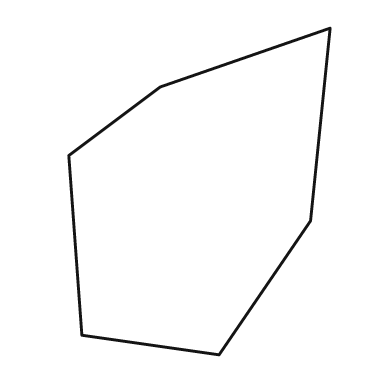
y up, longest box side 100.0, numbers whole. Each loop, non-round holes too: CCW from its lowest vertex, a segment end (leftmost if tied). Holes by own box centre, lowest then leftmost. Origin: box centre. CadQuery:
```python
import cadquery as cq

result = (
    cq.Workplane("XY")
    .moveTo(6.0, -50.0)
    .lineTo(34.0, -9.0)
    .lineTo(40.0, 50.0)
    .lineTo(-12.0, 32.0)
    .lineTo(-40.0, 11.0)
    .lineTo(-36.0, -44.0)
    .close()
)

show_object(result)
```